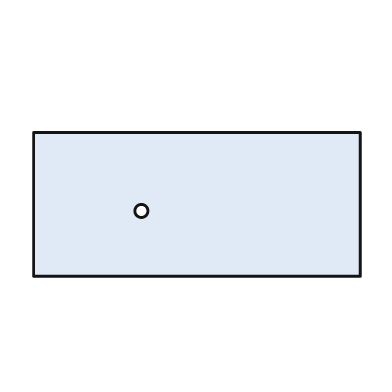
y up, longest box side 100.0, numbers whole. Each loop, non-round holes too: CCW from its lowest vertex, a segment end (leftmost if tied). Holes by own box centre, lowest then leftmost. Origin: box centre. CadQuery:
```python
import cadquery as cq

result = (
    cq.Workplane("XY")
    .moveTo(-50.0, -22.0)
    .lineTo(50.0, -22.0)
    .lineTo(50.0, 22.0)
    .lineTo(-50.0, 22.0)
    .close()
    .moveTo(-17.0, -2.0)
    .circle(2.0)
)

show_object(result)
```